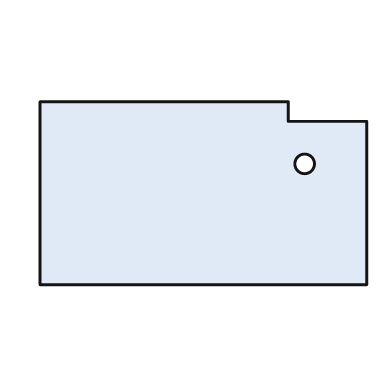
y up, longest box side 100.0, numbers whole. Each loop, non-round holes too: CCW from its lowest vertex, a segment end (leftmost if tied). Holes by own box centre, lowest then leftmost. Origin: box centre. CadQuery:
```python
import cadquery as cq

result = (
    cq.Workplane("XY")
    .moveTo(-50.0, -28.0)
    .lineTo(50.0, -28.0)
    .lineTo(50.0, 22.0)
    .lineTo(26.0, 22.0)
    .lineTo(26.0, 28.0)
    .lineTo(-50.0, 28.0)
    .close()
    .moveTo(31.0, 9.0)
    .circle(3.0)
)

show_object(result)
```